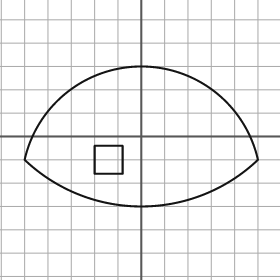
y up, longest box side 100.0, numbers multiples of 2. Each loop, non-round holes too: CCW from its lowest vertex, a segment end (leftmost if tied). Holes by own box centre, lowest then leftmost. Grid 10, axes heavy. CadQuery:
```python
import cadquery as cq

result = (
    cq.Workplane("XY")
    .moveTo(-50.0, -10.0)
    .threePointArc((0.0, -30.0), (50.0, -10.0))
    .threePointArc((0.0, 30.0), (-50.0, -10.0))
    .close()
    .moveTo(-20.0, -16.0)
    .lineTo(-8.0, -16.0)
    .lineTo(-8.0, -4.0)
    .lineTo(-20.0, -4.0)
    .close()
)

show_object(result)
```